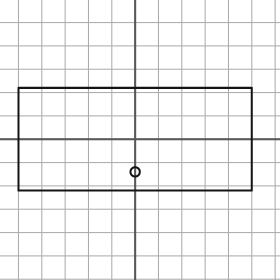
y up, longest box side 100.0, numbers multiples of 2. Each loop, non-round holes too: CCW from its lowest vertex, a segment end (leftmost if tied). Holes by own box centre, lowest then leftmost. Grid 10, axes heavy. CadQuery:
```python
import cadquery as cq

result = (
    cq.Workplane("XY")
    .moveTo(-50.0, -22.0)
    .lineTo(50.0, -22.0)
    .lineTo(50.0, 22.0)
    .lineTo(-50.0, 22.0)
    .close()
    .moveTo(0.0, -14.0)
    .circle(2.0)
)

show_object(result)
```